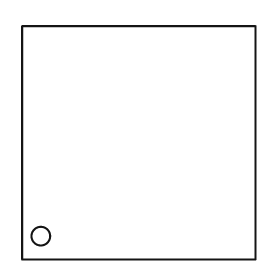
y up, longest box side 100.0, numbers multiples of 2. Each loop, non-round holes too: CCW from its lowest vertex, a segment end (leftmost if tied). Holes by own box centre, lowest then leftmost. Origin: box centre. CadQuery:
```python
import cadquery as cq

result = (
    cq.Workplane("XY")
    .moveTo(-50.0, -50.0)
    .lineTo(50.0, -50.0)
    .lineTo(50.0, 50.0)
    .lineTo(-50.0, 50.0)
    .close()
    .moveTo(-42.0, -40.0)
    .circle(4.0)
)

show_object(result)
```